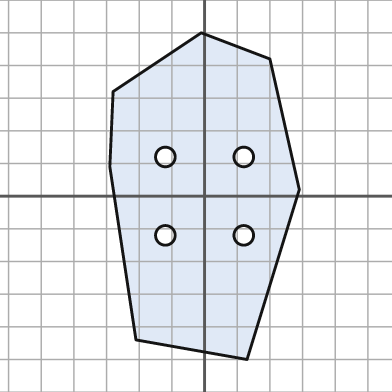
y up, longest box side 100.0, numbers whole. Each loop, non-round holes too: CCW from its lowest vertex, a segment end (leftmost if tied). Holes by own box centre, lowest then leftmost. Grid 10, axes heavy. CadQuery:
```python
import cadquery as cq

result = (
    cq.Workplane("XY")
    .moveTo(13.0, -50.0)
    .lineTo(29.0, 2.0)
    .lineTo(20.0, 42.0)
    .lineTo(-1.0, 50.0)
    .lineTo(-28.0, 32.0)
    .lineTo(-29.0, 9.0)
    .lineTo(-21.0, -44.0)
    .close()
    .moveTo(-12.0, -12.0)
    .circle(3.0)
    .moveTo(12.0, -12.0)
    .circle(3.0)
    .moveTo(-12.0, 12.0)
    .circle(3.0)
    .moveTo(12.0, 12.0)
    .circle(3.0)
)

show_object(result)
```